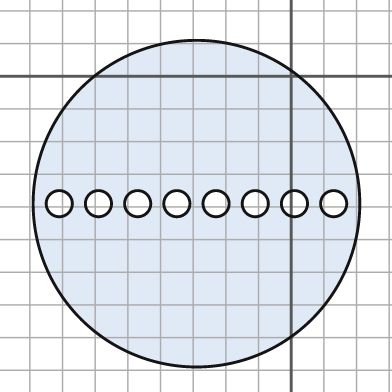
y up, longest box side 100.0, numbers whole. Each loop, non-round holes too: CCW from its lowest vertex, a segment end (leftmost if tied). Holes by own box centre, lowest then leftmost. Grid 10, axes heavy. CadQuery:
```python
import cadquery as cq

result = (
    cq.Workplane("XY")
    .moveTo(-29.0, -39.0)
    .circle(50.0)
    .moveTo(-71.0, -39.0)
    .circle(4.0)
    .moveTo(-59.0, -39.0)
    .circle(4.0)
    .moveTo(-47.0, -39.0)
    .circle(4.0)
    .moveTo(-35.0, -39.0)
    .circle(4.0)
    .moveTo(-23.0, -39.0)
    .circle(4.0)
    .moveTo(-11.0, -39.0)
    .circle(4.0)
    .moveTo(1.0, -39.0)
    .circle(4.0)
    .moveTo(13.0, -39.0)
    .circle(4.0)
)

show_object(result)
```